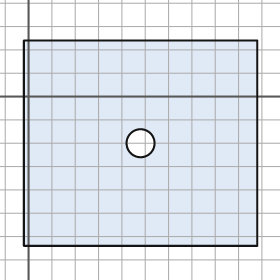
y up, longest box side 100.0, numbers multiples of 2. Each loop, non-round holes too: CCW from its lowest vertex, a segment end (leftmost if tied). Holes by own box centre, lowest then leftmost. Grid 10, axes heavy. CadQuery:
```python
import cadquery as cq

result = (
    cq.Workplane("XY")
    .moveTo(-2.0, -64.0)
    .lineTo(98.0, -64.0)
    .lineTo(98.0, 24.0)
    .lineTo(-2.0, 24.0)
    .close()
    .moveTo(48.0, -20.0)
    .circle(6.0)
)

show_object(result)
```